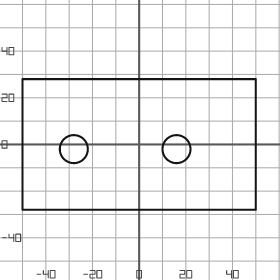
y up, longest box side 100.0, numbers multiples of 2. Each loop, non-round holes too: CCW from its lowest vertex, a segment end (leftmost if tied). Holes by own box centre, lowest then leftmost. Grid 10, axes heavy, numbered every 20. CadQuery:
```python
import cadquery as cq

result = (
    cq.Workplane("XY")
    .moveTo(-50.0, -28.0)
    .lineTo(50.0, -28.0)
    .lineTo(50.0, 28.0)
    .lineTo(-50.0, 28.0)
    .close()
    .moveTo(-28.0, -2.0)
    .circle(6.0)
    .moveTo(16.0, -2.0)
    .circle(6.0)
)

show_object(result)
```